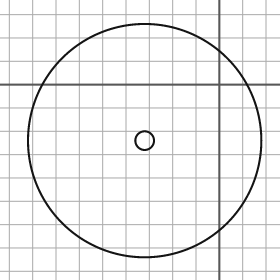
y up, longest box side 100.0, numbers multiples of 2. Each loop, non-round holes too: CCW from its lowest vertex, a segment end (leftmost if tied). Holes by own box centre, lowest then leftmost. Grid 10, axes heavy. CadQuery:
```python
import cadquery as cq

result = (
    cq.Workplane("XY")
    .moveTo(-32.0, -24.0)
    .circle(50.0)
    .moveTo(-32.0, -24.0)
    .circle(4.0)
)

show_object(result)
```